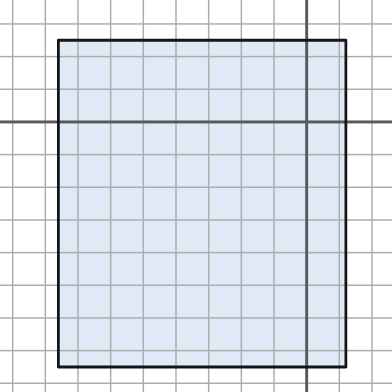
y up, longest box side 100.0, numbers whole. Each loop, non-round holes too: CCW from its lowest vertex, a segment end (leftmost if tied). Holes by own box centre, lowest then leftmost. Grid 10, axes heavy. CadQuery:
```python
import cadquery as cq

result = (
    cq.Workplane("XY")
    .moveTo(-76.0, -75.0)
    .lineTo(12.0, -75.0)
    .lineTo(12.0, 25.0)
    .lineTo(-76.0, 25.0)
    .close()
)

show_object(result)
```